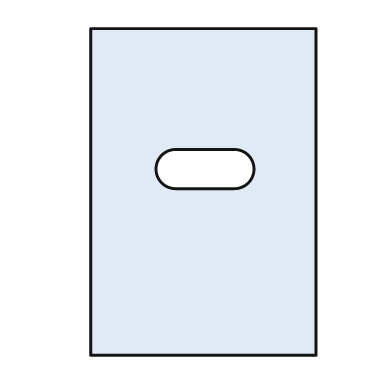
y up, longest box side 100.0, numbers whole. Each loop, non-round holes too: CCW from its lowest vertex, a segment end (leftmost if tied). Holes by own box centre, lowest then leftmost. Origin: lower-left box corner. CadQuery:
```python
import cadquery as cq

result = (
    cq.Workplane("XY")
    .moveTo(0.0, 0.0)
    .lineTo(69.0, 0.0)
    .lineTo(69.0, 100.0)
    .lineTo(0.0, 100.0)
    .close()
    .moveTo(26.0, 51.0)
    .lineTo(44.0, 51.0)
    .threePointArc((50.0, 57.0), (44.0, 63.0))
    .lineTo(26.0, 63.0)
    .threePointArc((20.0, 57.0), (26.0, 51.0))
    .close()
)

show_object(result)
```